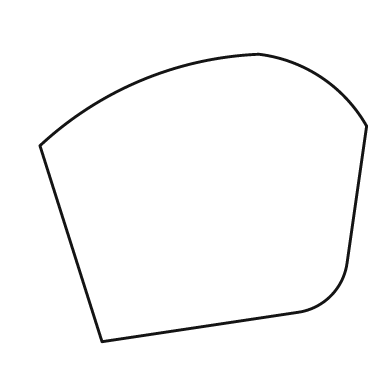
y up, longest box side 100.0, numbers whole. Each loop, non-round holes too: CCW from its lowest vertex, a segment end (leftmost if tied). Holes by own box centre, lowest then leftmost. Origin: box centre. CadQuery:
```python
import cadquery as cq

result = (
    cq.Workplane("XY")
    .moveTo(-31.0, -44.0)
    .lineTo(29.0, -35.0)
    .threePointArc((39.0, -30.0), (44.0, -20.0))
    .lineTo(50.0, 22.0)
    .threePointArc((36.0, 37.0), (17.0, 44.0))
    .threePointArc((-19.0, 36.0), (-50.0, 16.0))
    .close()
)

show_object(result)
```